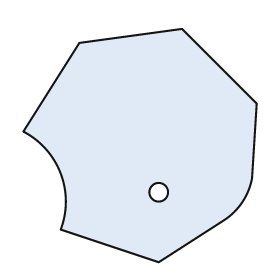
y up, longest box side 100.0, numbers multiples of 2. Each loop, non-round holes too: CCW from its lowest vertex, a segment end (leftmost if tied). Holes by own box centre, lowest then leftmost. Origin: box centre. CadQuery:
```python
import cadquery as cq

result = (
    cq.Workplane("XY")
    .moveTo(8.0, -50.0)
    .lineTo(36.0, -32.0)
    .threePointArc((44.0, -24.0), (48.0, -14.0))
    .lineTo(50.0, 18.0)
    .lineTo(18.0, 50.0)
    .lineTo(-26.0, 44.0)
    .lineTo(-50.0, 6.0)
    .threePointArc((-34.0, -12.0), (-34.0, -36.0))
    .close()
    .moveTo(8.0, -20.0)
    .circle(4.0)
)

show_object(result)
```